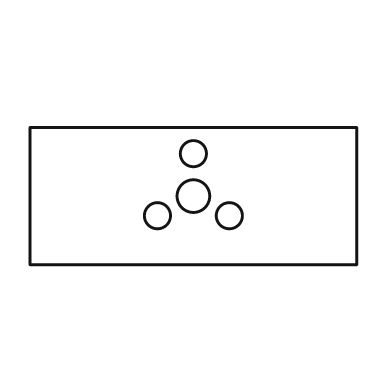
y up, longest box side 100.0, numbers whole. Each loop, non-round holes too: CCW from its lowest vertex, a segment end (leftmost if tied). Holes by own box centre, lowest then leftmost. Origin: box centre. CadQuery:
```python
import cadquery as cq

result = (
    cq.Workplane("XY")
    .moveTo(-50.0, -21.0)
    .lineTo(50.0, -21.0)
    .lineTo(50.0, 21.0)
    .lineTo(-50.0, 21.0)
    .close()
    .moveTo(-11.0, -6.0)
    .circle(4.0)
    .moveTo(11.0, -6.0)
    .circle(4.0)
    .moveTo(0.0, 0.0)
    .circle(5.0)
    .moveTo(0.0, 13.0)
    .circle(4.0)
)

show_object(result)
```